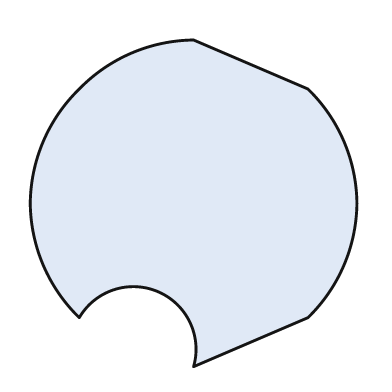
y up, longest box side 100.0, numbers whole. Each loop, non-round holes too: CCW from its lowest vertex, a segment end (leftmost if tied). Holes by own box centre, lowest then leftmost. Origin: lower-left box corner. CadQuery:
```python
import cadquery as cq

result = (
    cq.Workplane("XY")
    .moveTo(50.0, 0.0)
    .lineTo(85.0, 15.0)
    .threePointArc((96.0, 31.0), (100.0, 50.0))
    .threePointArc((96.0, 69.0), (85.0, 85.0))
    .lineTo(50.0, 100.0)
    .threePointArc((31.0, 96.0), (15.0, 85.0))
    .threePointArc((4.0, 69.0), (0.0, 50.0))
    .threePointArc((4.0, 31.0), (15.0, 15.0))
    .threePointArc((39.0, 23.0), (50.0, 0.0))
    .close()
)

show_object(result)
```